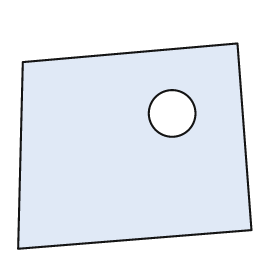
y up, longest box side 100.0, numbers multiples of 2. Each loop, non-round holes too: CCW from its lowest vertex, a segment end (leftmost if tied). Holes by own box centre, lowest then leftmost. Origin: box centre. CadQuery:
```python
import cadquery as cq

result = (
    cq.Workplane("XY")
    .moveTo(-50.0, -44.0)
    .lineTo(50.0, -36.0)
    .lineTo(44.0, 44.0)
    .lineTo(-48.0, 36.0)
    .close()
    .moveTo(16.0, 14.0)
    .circle(10.0)
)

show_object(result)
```